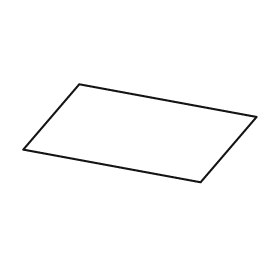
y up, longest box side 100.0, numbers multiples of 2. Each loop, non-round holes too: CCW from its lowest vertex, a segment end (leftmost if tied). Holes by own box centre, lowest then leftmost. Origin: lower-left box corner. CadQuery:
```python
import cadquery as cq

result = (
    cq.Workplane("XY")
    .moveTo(76.0, 0.0)
    .lineTo(100.0, 28.0)
    .lineTo(24.0, 42.0)
    .lineTo(0.0, 14.0)
    .close()
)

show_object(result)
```